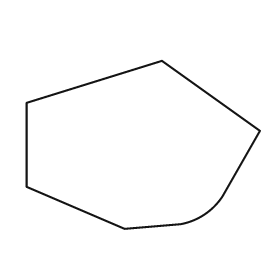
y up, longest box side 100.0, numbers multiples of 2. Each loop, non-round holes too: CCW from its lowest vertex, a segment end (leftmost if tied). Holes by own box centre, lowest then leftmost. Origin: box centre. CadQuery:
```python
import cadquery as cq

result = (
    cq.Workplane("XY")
    .moveTo(-8.0, -36.0)
    .lineTo(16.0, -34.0)
    .threePointArc((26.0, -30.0), (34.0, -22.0))
    .lineTo(50.0, 6.0)
    .lineTo(8.0, 36.0)
    .lineTo(-50.0, 18.0)
    .lineTo(-50.0, -18.0)
    .close()
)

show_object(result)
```